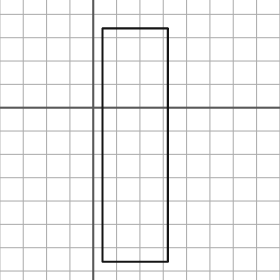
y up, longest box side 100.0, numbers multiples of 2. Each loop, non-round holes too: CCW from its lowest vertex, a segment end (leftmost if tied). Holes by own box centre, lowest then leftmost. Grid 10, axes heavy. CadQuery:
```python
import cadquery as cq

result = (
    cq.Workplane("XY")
    .moveTo(4.0, -66.0)
    .lineTo(32.0, -66.0)
    .lineTo(32.0, 34.0)
    .lineTo(4.0, 34.0)
    .close()
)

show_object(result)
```